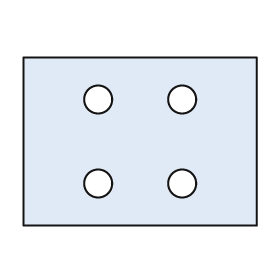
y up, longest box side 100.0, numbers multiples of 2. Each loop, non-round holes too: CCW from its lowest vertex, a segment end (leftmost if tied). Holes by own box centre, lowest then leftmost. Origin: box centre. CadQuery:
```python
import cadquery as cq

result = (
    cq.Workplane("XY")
    .moveTo(-50.0, -36.0)
    .lineTo(50.0, -36.0)
    .lineTo(50.0, 36.0)
    .lineTo(-50.0, 36.0)
    .close()
    .moveTo(-18.0, -18.0)
    .circle(6.0)
    .moveTo(18.0, -18.0)
    .circle(6.0)
    .moveTo(-18.0, 18.0)
    .circle(6.0)
    .moveTo(18.0, 18.0)
    .circle(6.0)
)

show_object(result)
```